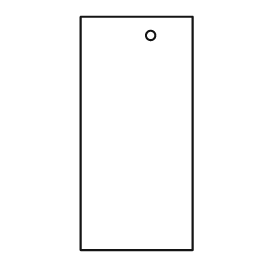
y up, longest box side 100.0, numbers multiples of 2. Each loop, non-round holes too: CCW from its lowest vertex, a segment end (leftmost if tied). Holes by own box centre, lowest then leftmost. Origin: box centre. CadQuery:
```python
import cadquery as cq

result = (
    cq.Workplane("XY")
    .moveTo(-24.0, -50.0)
    .lineTo(24.0, -50.0)
    .lineTo(24.0, 50.0)
    .lineTo(-24.0, 50.0)
    .close()
    .moveTo(6.0, 42.0)
    .circle(2.0)
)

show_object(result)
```